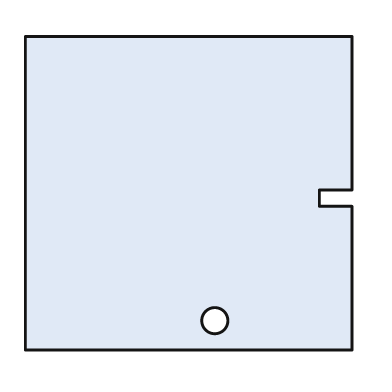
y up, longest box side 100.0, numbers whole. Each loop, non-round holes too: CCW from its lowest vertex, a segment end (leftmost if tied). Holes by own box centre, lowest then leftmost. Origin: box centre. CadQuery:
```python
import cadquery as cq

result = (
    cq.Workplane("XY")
    .moveTo(-50.0, -48.0)
    .lineTo(50.0, -48.0)
    .lineTo(50.0, -4.0)
    .lineTo(40.0, -4.0)
    .lineTo(40.0, 1.0)
    .lineTo(50.0, 1.0)
    .lineTo(50.0, 48.0)
    .lineTo(-50.0, 48.0)
    .close()
    .moveTo(8.0, -39.0)
    .circle(4.0)
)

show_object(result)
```